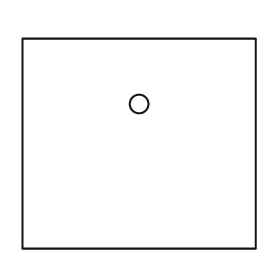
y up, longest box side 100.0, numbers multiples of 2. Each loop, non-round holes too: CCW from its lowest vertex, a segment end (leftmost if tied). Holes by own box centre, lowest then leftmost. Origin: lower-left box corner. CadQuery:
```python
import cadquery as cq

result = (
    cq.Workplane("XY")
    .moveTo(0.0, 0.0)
    .lineTo(100.0, 0.0)
    .lineTo(100.0, 90.0)
    .lineTo(0.0, 90.0)
    .close()
    .moveTo(50.0, 62.0)
    .circle(4.0)
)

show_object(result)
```